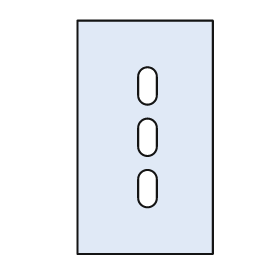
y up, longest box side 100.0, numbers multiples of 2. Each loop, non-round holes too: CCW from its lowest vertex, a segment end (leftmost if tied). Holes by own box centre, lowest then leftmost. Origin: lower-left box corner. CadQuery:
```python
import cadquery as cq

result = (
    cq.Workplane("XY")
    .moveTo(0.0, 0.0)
    .lineTo(58.0, 0.0)
    .lineTo(58.0, 100.0)
    .lineTo(0.0, 100.0)
    .close()
    .moveTo(26.0, 24.0)
    .threePointArc((30.0, 20.0), (34.0, 24.0))
    .lineTo(34.0, 32.0)
    .threePointArc((30.0, 36.0), (26.0, 32.0))
    .close()
    .moveTo(26.0, 46.0)
    .threePointArc((30.0, 42.0), (34.0, 46.0))
    .lineTo(34.0, 54.0)
    .threePointArc((30.0, 58.0), (26.0, 54.0))
    .close()
    .moveTo(26.0, 68.0)
    .threePointArc((30.0, 64.0), (34.0, 68.0))
    .lineTo(34.0, 76.0)
    .threePointArc((30.0, 80.0), (26.0, 76.0))
    .close()
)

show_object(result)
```